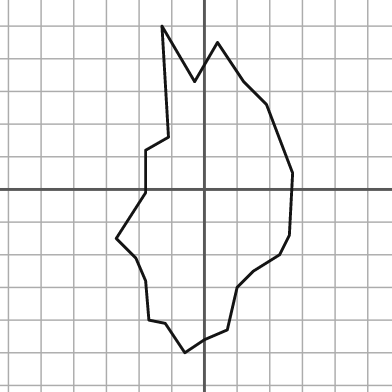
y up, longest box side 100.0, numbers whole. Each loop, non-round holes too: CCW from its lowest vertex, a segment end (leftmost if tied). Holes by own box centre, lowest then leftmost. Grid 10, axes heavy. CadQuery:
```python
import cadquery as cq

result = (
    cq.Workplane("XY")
    .moveTo(-6.0, -50.0)
    .lineTo(0.0, -46.0)
    .lineTo(7.0, -43.0)
    .lineTo(10.0, -30.0)
    .lineTo(15.0, -25.0)
    .lineTo(23.0, -20.0)
    .lineTo(26.0, -14.0)
    .lineTo(27.0, 5.0)
    .lineTo(19.0, 26.0)
    .lineTo(12.0, 33.0)
    .lineTo(4.0, 45.0)
    .lineTo(-3.0, 33.0)
    .lineTo(-13.0, 50.0)
    .lineTo(-11.0, 16.0)
    .lineTo(-18.0, 12.0)
    .lineTo(-18.0, -1.0)
    .lineTo(-27.0, -15.0)
    .lineTo(-21.0, -21.0)
    .lineTo(-18.0, -28.0)
    .lineTo(-17.0, -40.0)
    .lineTo(-12.0, -41.0)
    .close()
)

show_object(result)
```